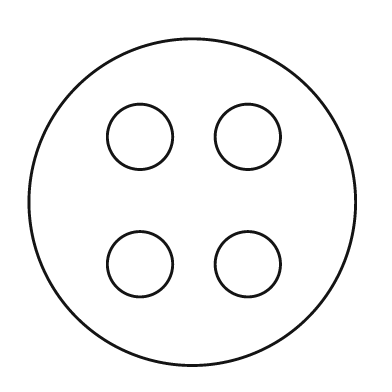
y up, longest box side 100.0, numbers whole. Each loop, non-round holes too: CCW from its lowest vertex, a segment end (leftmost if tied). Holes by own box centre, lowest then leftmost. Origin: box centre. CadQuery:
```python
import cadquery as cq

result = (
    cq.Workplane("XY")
    .moveTo(0.0, 0.0)
    .circle(50.0)
    .moveTo(-16.0, -19.0)
    .circle(10.0)
    .moveTo(17.0, -19.0)
    .circle(10.0)
    .moveTo(-16.0, 20.0)
    .circle(10.0)
    .moveTo(17.0, 20.0)
    .circle(10.0)
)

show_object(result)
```